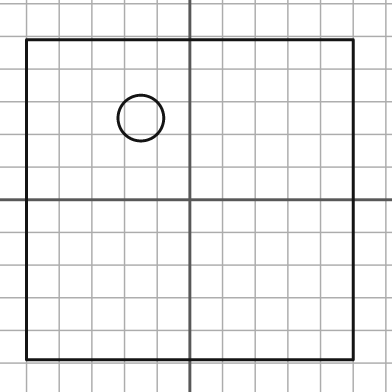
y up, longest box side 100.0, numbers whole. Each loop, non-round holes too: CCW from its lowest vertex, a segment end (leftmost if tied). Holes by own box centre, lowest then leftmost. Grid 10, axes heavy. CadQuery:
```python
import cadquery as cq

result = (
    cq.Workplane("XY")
    .moveTo(-50.0, -49.0)
    .lineTo(50.0, -49.0)
    .lineTo(50.0, 49.0)
    .lineTo(-50.0, 49.0)
    .close()
    .moveTo(-15.0, 25.0)
    .circle(7.0)
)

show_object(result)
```